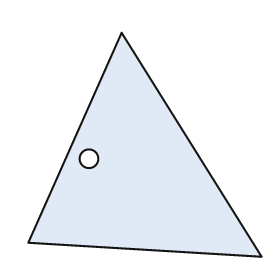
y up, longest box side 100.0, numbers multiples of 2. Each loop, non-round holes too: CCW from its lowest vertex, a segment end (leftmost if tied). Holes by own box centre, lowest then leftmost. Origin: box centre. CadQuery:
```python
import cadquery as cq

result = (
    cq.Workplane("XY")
    .moveTo(50.0, -48.0)
    .lineTo(-10.0, 48.0)
    .lineTo(-50.0, -42.0)
    .close()
    .moveTo(-24.0, -6.0)
    .circle(4.0)
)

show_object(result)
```